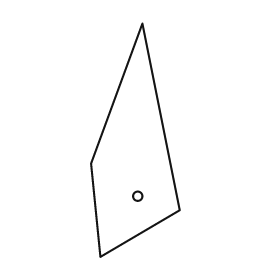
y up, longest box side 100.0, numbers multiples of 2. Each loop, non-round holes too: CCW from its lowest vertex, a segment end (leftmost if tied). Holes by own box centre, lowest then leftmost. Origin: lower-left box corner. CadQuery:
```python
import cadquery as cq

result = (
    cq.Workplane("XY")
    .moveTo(4.0, 0.0)
    .lineTo(38.0, 20.0)
    .lineTo(22.0, 100.0)
    .lineTo(0.0, 40.0)
    .close()
    .moveTo(20.0, 26.0)
    .circle(2.0)
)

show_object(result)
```